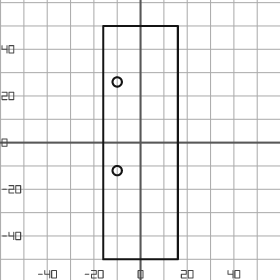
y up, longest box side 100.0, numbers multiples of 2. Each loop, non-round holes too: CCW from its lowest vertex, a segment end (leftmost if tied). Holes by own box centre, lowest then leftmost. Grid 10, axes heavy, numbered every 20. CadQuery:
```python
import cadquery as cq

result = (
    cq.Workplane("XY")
    .moveTo(-16.0, -50.0)
    .lineTo(16.0, -50.0)
    .lineTo(16.0, 50.0)
    .lineTo(-16.0, 50.0)
    .close()
    .moveTo(-10.0, -12.0)
    .circle(2.0)
    .moveTo(-10.0, 26.0)
    .circle(2.0)
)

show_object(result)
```